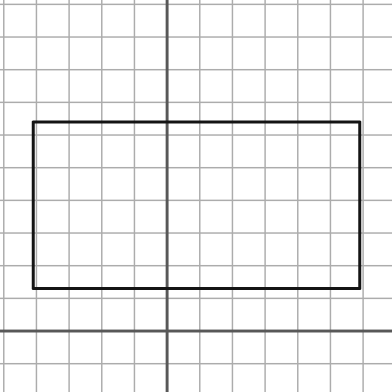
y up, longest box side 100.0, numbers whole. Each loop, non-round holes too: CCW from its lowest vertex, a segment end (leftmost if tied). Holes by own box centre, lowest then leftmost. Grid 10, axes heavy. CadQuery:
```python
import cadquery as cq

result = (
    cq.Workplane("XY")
    .moveTo(-41.0, 13.0)
    .lineTo(59.0, 13.0)
    .lineTo(59.0, 64.0)
    .lineTo(-41.0, 64.0)
    .close()
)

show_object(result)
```